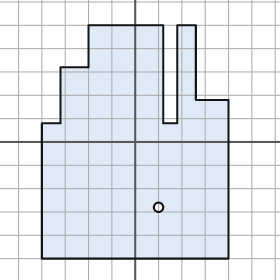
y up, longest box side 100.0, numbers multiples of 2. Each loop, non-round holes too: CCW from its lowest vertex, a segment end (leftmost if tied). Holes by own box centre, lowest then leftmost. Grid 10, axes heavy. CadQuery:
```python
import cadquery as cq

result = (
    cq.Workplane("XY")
    .moveTo(-40.0, -50.0)
    .lineTo(40.0, -50.0)
    .lineTo(40.0, 18.0)
    .lineTo(26.0, 18.0)
    .lineTo(26.0, 50.0)
    .lineTo(18.0, 50.0)
    .lineTo(18.0, 8.0)
    .lineTo(12.0, 8.0)
    .lineTo(12.0, 50.0)
    .lineTo(-20.0, 50.0)
    .lineTo(-20.0, 32.0)
    .lineTo(-32.0, 32.0)
    .lineTo(-32.0, 8.0)
    .lineTo(-40.0, 8.0)
    .close()
    .moveTo(10.0, -28.0)
    .circle(2.0)
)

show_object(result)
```